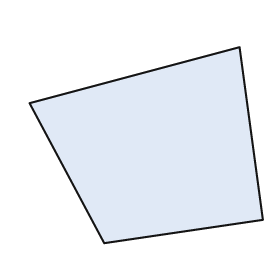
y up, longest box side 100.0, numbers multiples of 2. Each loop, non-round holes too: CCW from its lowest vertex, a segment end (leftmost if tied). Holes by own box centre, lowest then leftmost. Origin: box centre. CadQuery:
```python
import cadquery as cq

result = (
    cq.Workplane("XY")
    .moveTo(-18.0, -42.0)
    .lineTo(50.0, -32.0)
    .lineTo(40.0, 42.0)
    .lineTo(-50.0, 18.0)
    .close()
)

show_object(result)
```